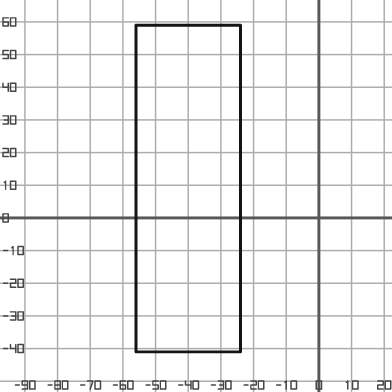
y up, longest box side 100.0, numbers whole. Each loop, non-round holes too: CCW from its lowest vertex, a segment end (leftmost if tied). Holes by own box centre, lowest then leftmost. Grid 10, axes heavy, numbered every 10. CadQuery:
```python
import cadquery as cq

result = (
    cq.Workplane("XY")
    .moveTo(-56.0, -41.0)
    .lineTo(-24.0, -41.0)
    .lineTo(-24.0, 59.0)
    .lineTo(-56.0, 59.0)
    .close()
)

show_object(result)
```